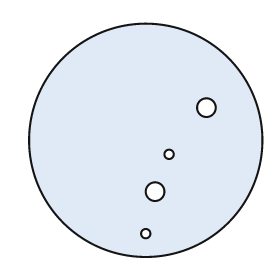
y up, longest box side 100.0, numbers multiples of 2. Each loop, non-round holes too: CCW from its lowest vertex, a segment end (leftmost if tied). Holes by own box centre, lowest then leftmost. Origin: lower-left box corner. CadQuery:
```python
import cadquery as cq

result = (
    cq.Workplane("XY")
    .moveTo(50.0, 50.0)
    .circle(50.0)
    .moveTo(50.0, 10.0)
    .circle(2.0)
    .moveTo(54.0, 28.0)
    .circle(4.0)
    .moveTo(60.0, 44.0)
    .circle(2.0)
    .moveTo(76.0, 64.0)
    .circle(4.0)
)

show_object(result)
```